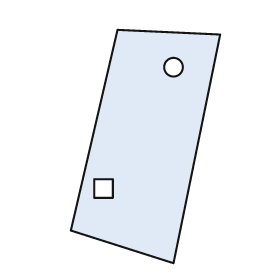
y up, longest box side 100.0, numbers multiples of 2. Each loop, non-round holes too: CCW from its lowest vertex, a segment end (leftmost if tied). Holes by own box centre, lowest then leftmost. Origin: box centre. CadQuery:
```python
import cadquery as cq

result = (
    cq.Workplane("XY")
    .moveTo(12.0, -50.0)
    .lineTo(32.0, 48.0)
    .lineTo(-12.0, 50.0)
    .lineTo(-32.0, -36.0)
    .close()
    .moveTo(-22.0, -22.0)
    .lineTo(-14.0, -22.0)
    .lineTo(-14.0, -14.0)
    .lineTo(-22.0, -14.0)
    .close()
    .moveTo(12.0, 34.0)
    .circle(4.0)
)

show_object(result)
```